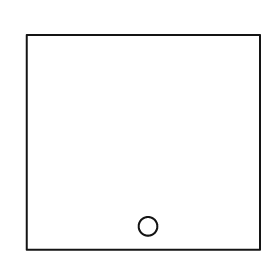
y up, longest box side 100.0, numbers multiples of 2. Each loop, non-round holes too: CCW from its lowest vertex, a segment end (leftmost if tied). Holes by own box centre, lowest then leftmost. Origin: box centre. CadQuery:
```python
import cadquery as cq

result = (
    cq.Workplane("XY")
    .moveTo(-50.0, -46.0)
    .lineTo(50.0, -46.0)
    .lineTo(50.0, 46.0)
    .lineTo(-50.0, 46.0)
    .close()
    .moveTo(2.0, -36.0)
    .circle(4.0)
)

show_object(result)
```